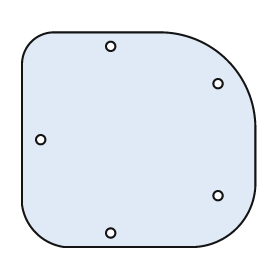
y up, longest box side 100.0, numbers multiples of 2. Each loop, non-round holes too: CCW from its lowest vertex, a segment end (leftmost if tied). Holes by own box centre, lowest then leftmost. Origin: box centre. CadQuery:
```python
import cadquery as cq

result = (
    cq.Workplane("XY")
    .moveTo(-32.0, -46.0)
    .lineTo(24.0, -46.0)
    .threePointArc((42.0, -38.0), (50.0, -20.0))
    .lineTo(50.0, 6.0)
    .threePointArc((38.0, 34.0), (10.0, 46.0))
    .lineTo(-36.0, 46.0)
    .threePointArc((-46.0, 42.0), (-50.0, 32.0))
    .lineTo(-50.0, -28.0)
    .threePointArc((-44.0, -40.0), (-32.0, -46.0))
    .close()
    .moveTo(-12.0, -40.0)
    .circle(2.0)
    .moveTo(34.0, -24.0)
    .circle(2.0)
    .moveTo(-42.0, 0.0)
    .circle(2.0)
    .moveTo(34.0, 24.0)
    .circle(2.0)
    .moveTo(-12.0, 40.0)
    .circle(2.0)
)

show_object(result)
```